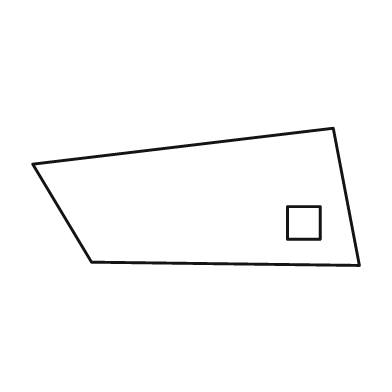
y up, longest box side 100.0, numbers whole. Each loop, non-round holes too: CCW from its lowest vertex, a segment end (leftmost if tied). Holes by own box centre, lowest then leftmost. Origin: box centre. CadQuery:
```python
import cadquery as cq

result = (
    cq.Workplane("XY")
    .moveTo(50.0, -21.0)
    .lineTo(42.0, 21.0)
    .lineTo(-50.0, 10.0)
    .lineTo(-32.0, -20.0)
    .close()
    .moveTo(28.0, -13.0)
    .lineTo(38.0, -13.0)
    .lineTo(38.0, -3.0)
    .lineTo(28.0, -3.0)
    .close()
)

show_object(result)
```